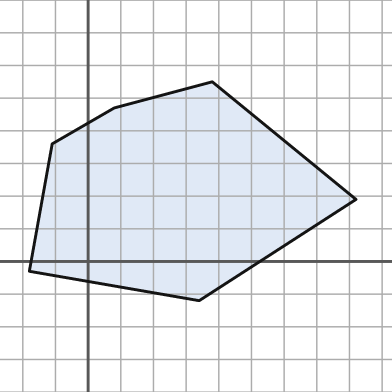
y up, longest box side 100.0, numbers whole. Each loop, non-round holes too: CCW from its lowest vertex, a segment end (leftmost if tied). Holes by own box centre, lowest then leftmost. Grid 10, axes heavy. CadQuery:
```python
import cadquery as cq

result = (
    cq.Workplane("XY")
    .moveTo(34.0, -12.0)
    .lineTo(82.0, 19.0)
    .lineTo(38.0, 55.0)
    .lineTo(8.0, 47.0)
    .lineTo(-11.0, 36.0)
    .lineTo(-18.0, -3.0)
    .close()
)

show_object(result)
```